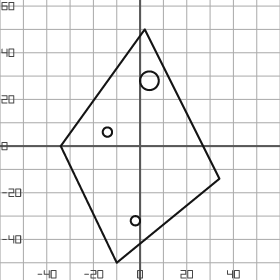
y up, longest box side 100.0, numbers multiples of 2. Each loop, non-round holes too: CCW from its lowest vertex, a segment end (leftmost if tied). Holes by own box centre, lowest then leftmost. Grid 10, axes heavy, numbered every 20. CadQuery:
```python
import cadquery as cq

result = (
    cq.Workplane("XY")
    .moveTo(-10.0, -50.0)
    .lineTo(34.0, -14.0)
    .lineTo(2.0, 50.0)
    .lineTo(-34.0, 0.0)
    .close()
    .moveTo(-2.0, -32.0)
    .circle(2.0)
    .moveTo(-14.0, 6.0)
    .circle(2.0)
    .moveTo(4.0, 28.0)
    .circle(4.0)
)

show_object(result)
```